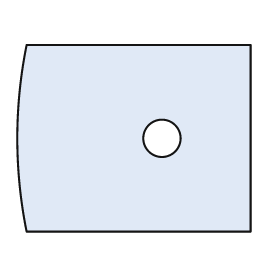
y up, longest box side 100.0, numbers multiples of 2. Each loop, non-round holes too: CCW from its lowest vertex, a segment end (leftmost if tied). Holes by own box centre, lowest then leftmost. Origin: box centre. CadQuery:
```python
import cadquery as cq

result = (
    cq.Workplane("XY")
    .moveTo(-46.0, -40.0)
    .lineTo(50.0, -40.0)
    .lineTo(50.0, 40.0)
    .lineTo(-46.0, 40.0)
    .threePointArc((-50.0, 0.0), (-46.0, -40.0))
    .close()
    .moveTo(12.0, 0.0)
    .circle(8.0)
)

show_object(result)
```